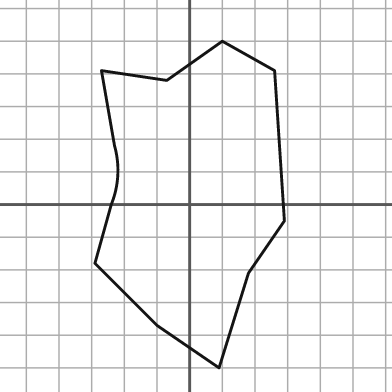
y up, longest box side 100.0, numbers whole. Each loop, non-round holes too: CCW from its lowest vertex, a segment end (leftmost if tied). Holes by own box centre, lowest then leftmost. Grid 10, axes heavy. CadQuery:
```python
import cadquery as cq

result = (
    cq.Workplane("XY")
    .moveTo(9.0, -50.0)
    .lineTo(18.0, -21.0)
    .lineTo(29.0, -5.0)
    .lineTo(26.0, 41.0)
    .lineTo(10.0, 50.0)
    .lineTo(-7.0, 38.0)
    .lineTo(-27.0, 41.0)
    .lineTo(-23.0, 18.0)
    .threePointArc((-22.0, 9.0), (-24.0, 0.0))
    .lineTo(-29.0, -18.0)
    .lineTo(-10.0, -37.0)
    .close()
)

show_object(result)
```